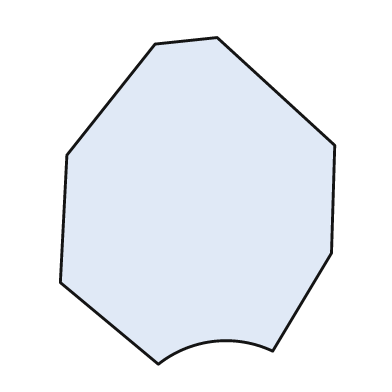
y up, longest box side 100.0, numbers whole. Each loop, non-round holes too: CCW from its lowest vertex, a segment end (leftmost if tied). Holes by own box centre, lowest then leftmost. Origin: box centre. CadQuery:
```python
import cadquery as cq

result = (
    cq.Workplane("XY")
    .moveTo(-12.0, -50.0)
    .threePointArc((5.0, -43.0), (23.0, -46.0))
    .lineTo(41.0, -16.0)
    .lineTo(42.0, 17.0)
    .lineTo(6.0, 50.0)
    .lineTo(-13.0, 48.0)
    .lineTo(-40.0, 14.0)
    .lineTo(-42.0, -25.0)
    .close()
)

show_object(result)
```